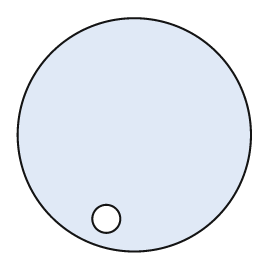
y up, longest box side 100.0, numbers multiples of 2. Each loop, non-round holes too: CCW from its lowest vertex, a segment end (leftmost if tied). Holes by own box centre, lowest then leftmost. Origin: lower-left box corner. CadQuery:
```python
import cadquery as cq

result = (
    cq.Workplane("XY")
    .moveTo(50.0, 50.0)
    .circle(50.0)
    .moveTo(38.0, 14.0)
    .circle(6.0)
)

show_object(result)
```